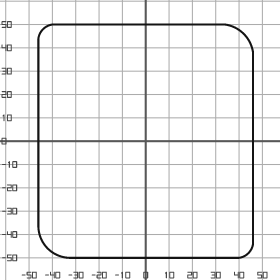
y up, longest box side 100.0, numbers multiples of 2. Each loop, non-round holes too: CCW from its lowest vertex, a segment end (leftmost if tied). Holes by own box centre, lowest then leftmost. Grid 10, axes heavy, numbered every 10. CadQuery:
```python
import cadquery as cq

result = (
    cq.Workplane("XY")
    .moveTo(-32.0, -50.0)
    .lineTo(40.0, -50.0)
    .threePointArc((44.0, -48.0), (46.0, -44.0))
    .lineTo(46.0, 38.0)
    .threePointArc((42.0, 46.0), (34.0, 50.0))
    .lineTo(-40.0, 50.0)
    .threePointArc((-44.0, 48.0), (-46.0, 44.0))
    .lineTo(-46.0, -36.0)
    .threePointArc((-42.0, -46.0), (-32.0, -50.0))
    .close()
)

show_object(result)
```